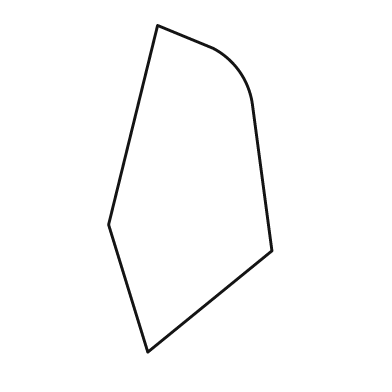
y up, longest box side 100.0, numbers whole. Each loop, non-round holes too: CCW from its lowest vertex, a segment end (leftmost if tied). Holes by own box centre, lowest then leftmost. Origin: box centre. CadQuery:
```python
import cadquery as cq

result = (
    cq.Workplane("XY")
    .moveTo(-13.0, -50.0)
    .lineTo(25.0, -19.0)
    .lineTo(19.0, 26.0)
    .threePointArc((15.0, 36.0), (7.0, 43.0))
    .lineTo(-10.0, 50.0)
    .lineTo(-25.0, -11.0)
    .close()
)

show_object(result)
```